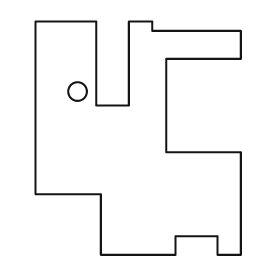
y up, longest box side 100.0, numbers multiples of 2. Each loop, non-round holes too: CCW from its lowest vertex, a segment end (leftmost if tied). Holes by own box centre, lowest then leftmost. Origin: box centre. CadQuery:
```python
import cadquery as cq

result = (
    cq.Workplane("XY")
    .moveTo(-16.0, -50.0)
    .lineTo(16.0, -50.0)
    .lineTo(16.0, -42.0)
    .lineTo(34.0, -42.0)
    .lineTo(34.0, -50.0)
    .lineTo(44.0, -50.0)
    .lineTo(44.0, -6.0)
    .lineTo(12.0, -6.0)
    .lineTo(12.0, 34.0)
    .lineTo(44.0, 34.0)
    .lineTo(44.0, 46.0)
    .lineTo(6.0, 46.0)
    .lineTo(6.0, 50.0)
    .lineTo(-4.0, 50.0)
    .lineTo(-4.0, 14.0)
    .lineTo(-18.0, 14.0)
    .lineTo(-18.0, 50.0)
    .lineTo(-44.0, 50.0)
    .lineTo(-44.0, -24.0)
    .lineTo(-16.0, -24.0)
    .close()
    .moveTo(-26.0, 20.0)
    .circle(4.0)
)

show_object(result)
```